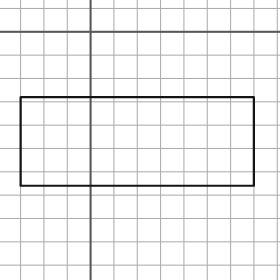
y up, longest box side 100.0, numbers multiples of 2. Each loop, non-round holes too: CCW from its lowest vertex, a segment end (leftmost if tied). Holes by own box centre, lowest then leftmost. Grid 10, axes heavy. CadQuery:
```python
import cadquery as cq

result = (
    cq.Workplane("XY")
    .moveTo(-30.0, -66.0)
    .lineTo(70.0, -66.0)
    .lineTo(70.0, -28.0)
    .lineTo(-30.0, -28.0)
    .close()
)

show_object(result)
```